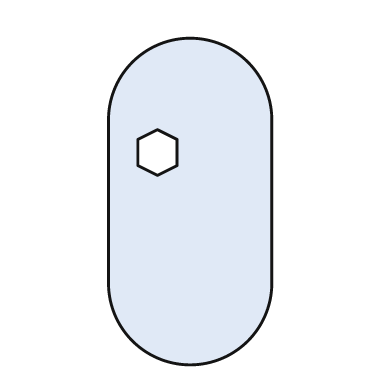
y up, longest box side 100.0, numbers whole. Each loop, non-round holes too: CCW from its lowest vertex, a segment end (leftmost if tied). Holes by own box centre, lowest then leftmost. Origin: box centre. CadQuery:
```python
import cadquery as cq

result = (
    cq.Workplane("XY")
    .moveTo(-25.0, -25.0)
    .threePointArc((0.0, -50.0), (25.0, -25.0))
    .lineTo(25.0, 25.0)
    .threePointArc((0.0, 50.0), (-25.0, 25.0))
    .close()
    .moveTo(-10.0, 8.0)
    .lineTo(-4.0, 11.0)
    .lineTo(-4.0, 19.0)
    .lineTo(-10.0, 22.0)
    .lineTo(-16.0, 19.0)
    .lineTo(-16.0, 11.0)
    .close()
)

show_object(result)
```